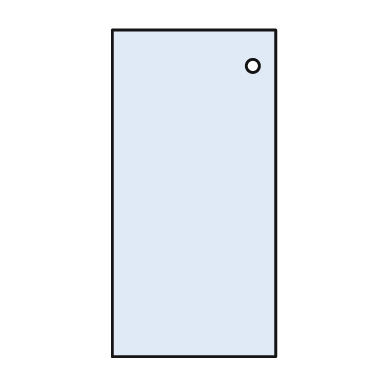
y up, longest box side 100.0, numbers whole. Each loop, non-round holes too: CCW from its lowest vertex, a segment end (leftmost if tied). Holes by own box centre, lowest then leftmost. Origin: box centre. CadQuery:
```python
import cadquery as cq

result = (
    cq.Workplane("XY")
    .moveTo(-25.0, -50.0)
    .lineTo(25.0, -50.0)
    .lineTo(25.0, 50.0)
    .lineTo(-25.0, 50.0)
    .close()
    .moveTo(18.0, 39.0)
    .circle(2.0)
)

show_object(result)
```